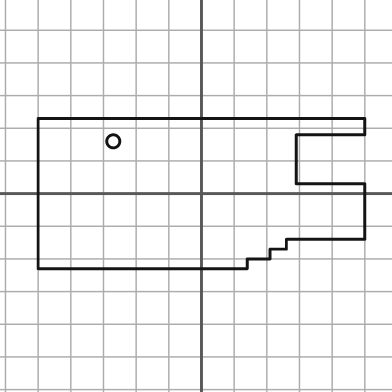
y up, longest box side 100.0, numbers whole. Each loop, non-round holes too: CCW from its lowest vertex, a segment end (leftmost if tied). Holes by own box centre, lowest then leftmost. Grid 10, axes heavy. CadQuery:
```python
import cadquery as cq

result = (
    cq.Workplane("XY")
    .moveTo(-50.0, -23.0)
    .lineTo(14.0, -23.0)
    .lineTo(14.0, -20.0)
    .lineTo(21.0, -20.0)
    .lineTo(21.0, -17.0)
    .lineTo(26.0, -17.0)
    .lineTo(26.0, -14.0)
    .lineTo(50.0, -14.0)
    .lineTo(50.0, 3.0)
    .lineTo(29.0, 3.0)
    .lineTo(29.0, 18.0)
    .lineTo(50.0, 18.0)
    .lineTo(50.0, 23.0)
    .lineTo(-50.0, 23.0)
    .close()
    .moveTo(-27.0, 16.0)
    .circle(2.0)
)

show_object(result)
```